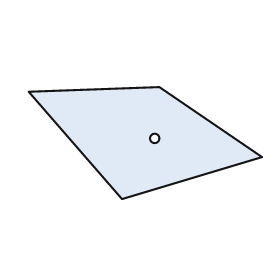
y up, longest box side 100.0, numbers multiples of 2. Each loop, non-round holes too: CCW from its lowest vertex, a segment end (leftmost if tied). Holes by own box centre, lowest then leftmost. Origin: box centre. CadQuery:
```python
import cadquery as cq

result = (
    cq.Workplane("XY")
    .moveTo(-10.0, -24.0)
    .lineTo(50.0, -6.0)
    .lineTo(6.0, 24.0)
    .lineTo(-50.0, 22.0)
    .close()
    .moveTo(4.0, 2.0)
    .circle(2.0)
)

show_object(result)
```